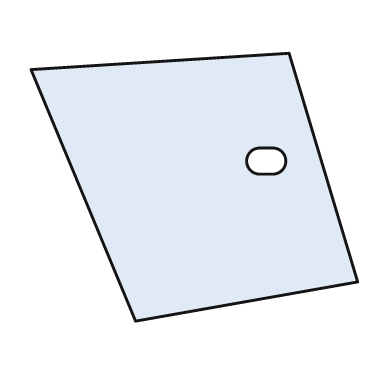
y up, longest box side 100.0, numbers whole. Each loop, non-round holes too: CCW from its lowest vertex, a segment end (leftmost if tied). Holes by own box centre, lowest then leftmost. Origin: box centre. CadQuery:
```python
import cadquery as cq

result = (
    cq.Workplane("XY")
    .moveTo(-18.0, -41.0)
    .lineTo(50.0, -29.0)
    .lineTo(29.0, 41.0)
    .lineTo(-50.0, 36.0)
    .close()
    .moveTo(20.0, 4.0)
    .lineTo(24.0, 4.0)
    .threePointArc((28.0, 8.0), (24.0, 12.0))
    .lineTo(20.0, 12.0)
    .threePointArc((16.0, 8.0), (20.0, 4.0))
    .close()
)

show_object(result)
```